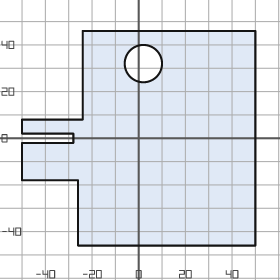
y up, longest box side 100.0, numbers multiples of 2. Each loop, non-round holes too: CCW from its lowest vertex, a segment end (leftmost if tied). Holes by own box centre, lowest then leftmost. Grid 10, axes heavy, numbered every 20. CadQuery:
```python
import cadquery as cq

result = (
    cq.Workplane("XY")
    .moveTo(-26.0, -46.0)
    .lineTo(50.0, -46.0)
    .lineTo(50.0, 46.0)
    .lineTo(-24.0, 46.0)
    .lineTo(-24.0, 8.0)
    .lineTo(-50.0, 8.0)
    .lineTo(-50.0, 2.0)
    .lineTo(-28.0, 2.0)
    .lineTo(-28.0, -2.0)
    .lineTo(-50.0, -2.0)
    .lineTo(-50.0, -18.0)
    .lineTo(-26.0, -18.0)
    .close()
    .moveTo(2.0, 32.0)
    .circle(8.0)
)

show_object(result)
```